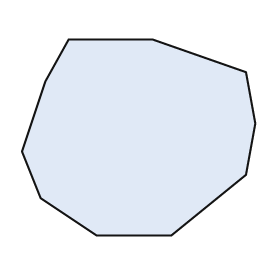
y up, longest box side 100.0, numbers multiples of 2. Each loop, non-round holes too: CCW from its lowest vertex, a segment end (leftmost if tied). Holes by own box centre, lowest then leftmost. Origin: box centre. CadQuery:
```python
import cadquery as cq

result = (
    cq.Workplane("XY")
    .moveTo(-18.0, -42.0)
    .lineTo(14.0, -42.0)
    .lineTo(46.0, -16.0)
    .lineTo(50.0, 6.0)
    .lineTo(46.0, 28.0)
    .lineTo(6.0, 42.0)
    .lineTo(-30.0, 42.0)
    .lineTo(-40.0, 24.0)
    .lineTo(-50.0, -6.0)
    .lineTo(-42.0, -26.0)
    .close()
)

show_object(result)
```